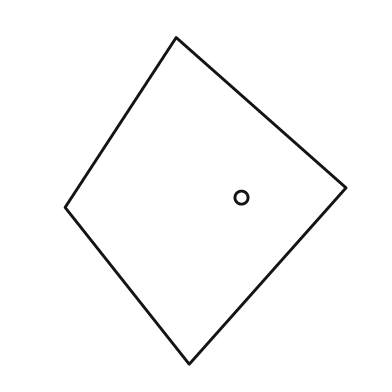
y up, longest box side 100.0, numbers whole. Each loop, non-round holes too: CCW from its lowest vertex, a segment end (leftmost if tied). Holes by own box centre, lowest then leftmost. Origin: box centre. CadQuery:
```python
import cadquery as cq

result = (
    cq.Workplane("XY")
    .moveTo(-5.0, -50.0)
    .lineTo(43.0, 4.0)
    .lineTo(-9.0, 50.0)
    .lineTo(-43.0, -2.0)
    .close()
    .moveTo(11.0, 1.0)
    .circle(2.0)
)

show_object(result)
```